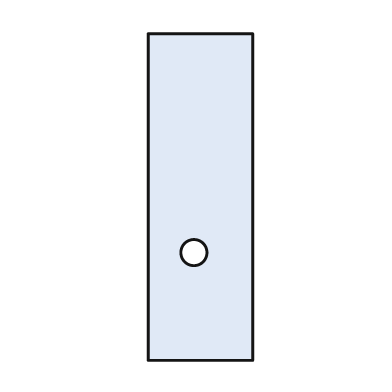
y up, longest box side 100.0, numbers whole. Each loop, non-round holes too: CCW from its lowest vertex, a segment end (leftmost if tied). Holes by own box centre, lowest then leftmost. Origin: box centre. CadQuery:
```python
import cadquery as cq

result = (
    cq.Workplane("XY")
    .moveTo(-16.0, -50.0)
    .lineTo(16.0, -50.0)
    .lineTo(16.0, 50.0)
    .lineTo(-16.0, 50.0)
    .close()
    .moveTo(-2.0, -17.0)
    .circle(4.0)
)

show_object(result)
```